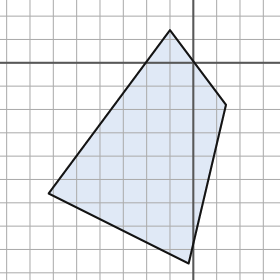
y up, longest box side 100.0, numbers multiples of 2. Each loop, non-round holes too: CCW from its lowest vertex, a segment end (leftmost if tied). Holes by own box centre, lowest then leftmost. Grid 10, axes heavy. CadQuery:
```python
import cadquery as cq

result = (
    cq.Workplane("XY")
    .moveTo(-2.0, -86.0)
    .lineTo(14.0, -18.0)
    .lineTo(-10.0, 14.0)
    .lineTo(-62.0, -56.0)
    .close()
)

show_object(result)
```